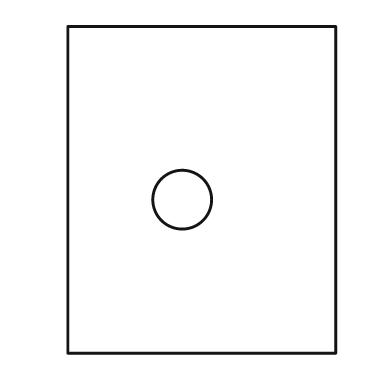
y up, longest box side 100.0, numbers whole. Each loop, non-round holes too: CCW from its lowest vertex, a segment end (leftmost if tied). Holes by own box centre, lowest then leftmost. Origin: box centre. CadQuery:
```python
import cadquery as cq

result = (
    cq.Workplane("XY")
    .moveTo(-41.0, -50.0)
    .lineTo(41.0, -50.0)
    .lineTo(41.0, 50.0)
    .lineTo(-41.0, 50.0)
    .close()
    .moveTo(-6.0, -3.0)
    .circle(9.0)
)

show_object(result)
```